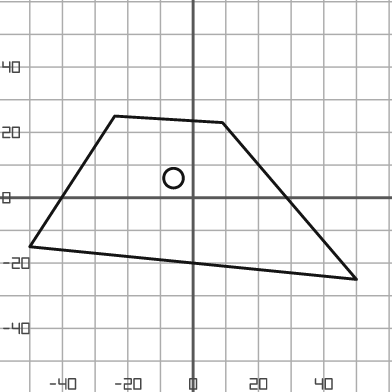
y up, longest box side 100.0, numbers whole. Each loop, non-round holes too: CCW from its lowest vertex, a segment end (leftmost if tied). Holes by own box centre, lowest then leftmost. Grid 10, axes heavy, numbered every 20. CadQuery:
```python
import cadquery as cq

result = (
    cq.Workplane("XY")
    .moveTo(50.0, -25.0)
    .lineTo(9.0, 23.0)
    .lineTo(-24.0, 25.0)
    .lineTo(-50.0, -15.0)
    .close()
    .moveTo(-6.0, 6.0)
    .circle(3.0)
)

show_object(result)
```